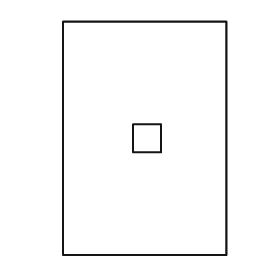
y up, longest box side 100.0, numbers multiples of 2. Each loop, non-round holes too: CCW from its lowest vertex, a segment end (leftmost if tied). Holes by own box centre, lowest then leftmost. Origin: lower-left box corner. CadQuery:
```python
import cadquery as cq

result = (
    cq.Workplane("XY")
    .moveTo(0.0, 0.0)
    .lineTo(70.0, 0.0)
    .lineTo(70.0, 100.0)
    .lineTo(0.0, 100.0)
    .close()
    .moveTo(30.0, 44.0)
    .lineTo(42.0, 44.0)
    .lineTo(42.0, 56.0)
    .lineTo(30.0, 56.0)
    .close()
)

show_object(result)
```